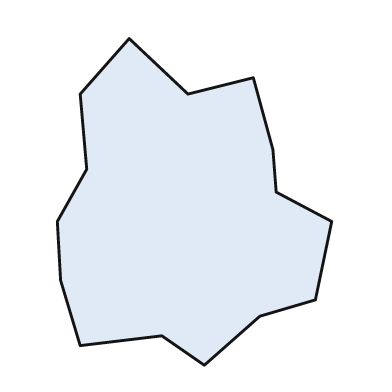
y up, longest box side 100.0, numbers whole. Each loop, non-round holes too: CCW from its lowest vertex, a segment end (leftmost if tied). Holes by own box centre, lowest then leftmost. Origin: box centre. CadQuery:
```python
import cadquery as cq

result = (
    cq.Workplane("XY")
    .moveTo(3.0, -50.0)
    .lineTo(20.0, -35.0)
    .lineTo(37.0, -30.0)
    .lineTo(42.0, -6.0)
    .lineTo(25.0, 3.0)
    .lineTo(24.0, 16.0)
    .lineTo(18.0, 38.0)
    .lineTo(-2.0, 33.0)
    .lineTo(-20.0, 50.0)
    .lineTo(-35.0, 33.0)
    .lineTo(-33.0, 10.0)
    .lineTo(-42.0, -6.0)
    .lineTo(-41.0, -24.0)
    .lineTo(-35.0, -44.0)
    .lineTo(-10.0, -41.0)
    .close()
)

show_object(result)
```